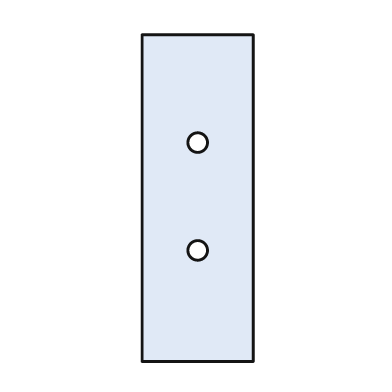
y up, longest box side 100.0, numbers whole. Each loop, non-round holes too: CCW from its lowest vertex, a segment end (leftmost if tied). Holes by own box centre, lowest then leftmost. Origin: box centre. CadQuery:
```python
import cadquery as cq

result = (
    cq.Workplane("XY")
    .moveTo(-17.0, -50.0)
    .lineTo(17.0, -50.0)
    .lineTo(17.0, 50.0)
    .lineTo(-17.0, 50.0)
    .close()
    .moveTo(0.0, -16.0)
    .circle(3.0)
    .moveTo(0.0, 17.0)
    .circle(3.0)
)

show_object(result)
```